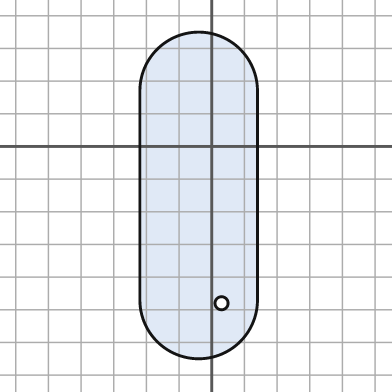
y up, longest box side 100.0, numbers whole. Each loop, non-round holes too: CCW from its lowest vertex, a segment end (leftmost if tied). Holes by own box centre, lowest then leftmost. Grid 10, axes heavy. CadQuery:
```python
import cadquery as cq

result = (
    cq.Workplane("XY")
    .moveTo(-22.0, -47.0)
    .threePointArc((-4.0, -65.0), (14.0, -47.0))
    .lineTo(14.0, 17.0)
    .threePointArc((-4.0, 35.0), (-22.0, 17.0))
    .close()
    .moveTo(3.0, -48.0)
    .circle(2.0)
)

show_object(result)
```